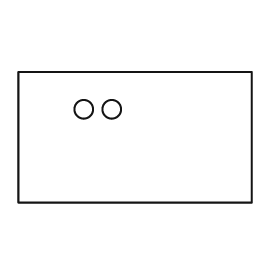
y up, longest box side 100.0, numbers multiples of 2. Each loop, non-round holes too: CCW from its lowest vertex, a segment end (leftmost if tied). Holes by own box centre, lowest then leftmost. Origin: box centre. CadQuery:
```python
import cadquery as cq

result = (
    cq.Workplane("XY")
    .moveTo(-50.0, -28.0)
    .lineTo(50.0, -28.0)
    .lineTo(50.0, 28.0)
    .lineTo(-50.0, 28.0)
    .close()
    .moveTo(-22.0, 12.0)
    .circle(4.0)
    .moveTo(-10.0, 12.0)
    .circle(4.0)
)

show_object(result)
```